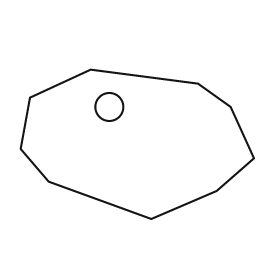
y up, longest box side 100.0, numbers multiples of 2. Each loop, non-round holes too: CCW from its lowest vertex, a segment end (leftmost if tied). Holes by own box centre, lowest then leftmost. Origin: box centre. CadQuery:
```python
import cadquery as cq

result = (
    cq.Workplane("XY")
    .moveTo(6.0, -32.0)
    .lineTo(34.0, -20.0)
    .lineTo(50.0, -6.0)
    .lineTo(40.0, 16.0)
    .lineTo(26.0, 26.0)
    .lineTo(-20.0, 32.0)
    .lineTo(-46.0, 20.0)
    .lineTo(-50.0, -2.0)
    .lineTo(-38.0, -16.0)
    .close()
    .moveTo(-12.0, 16.0)
    .circle(6.0)
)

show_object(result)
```